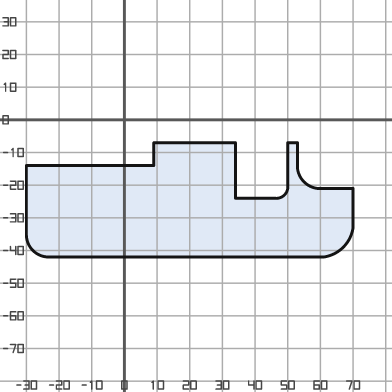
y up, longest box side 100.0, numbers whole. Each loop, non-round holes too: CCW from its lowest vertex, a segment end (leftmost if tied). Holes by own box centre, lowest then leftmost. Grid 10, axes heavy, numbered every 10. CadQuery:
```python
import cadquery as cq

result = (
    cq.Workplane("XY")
    .moveTo(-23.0, -42.0)
    .lineTo(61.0, -42.0)
    .threePointArc((67.0, -39.0), (70.0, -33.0))
    .lineTo(70.0, -21.0)
    .lineTo(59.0, -21.0)
    .threePointArc((55.0, -19.0), (53.0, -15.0))
    .lineTo(53.0, -7.0)
    .lineTo(50.0, -7.0)
    .lineTo(50.0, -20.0)
    .threePointArc((49.0, -23.0), (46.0, -24.0))
    .lineTo(34.0, -24.0)
    .lineTo(34.0, -7.0)
    .lineTo(9.0, -7.0)
    .lineTo(9.0, -14.0)
    .lineTo(-30.0, -14.0)
    .lineTo(-30.0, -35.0)
    .threePointArc((-28.0, -40.0), (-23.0, -42.0))
    .close()
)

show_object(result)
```